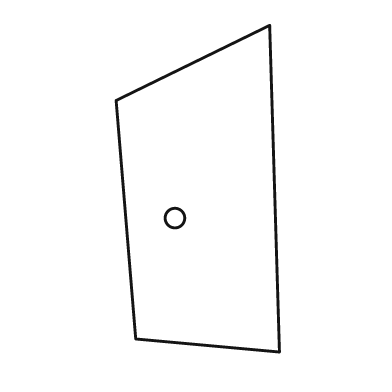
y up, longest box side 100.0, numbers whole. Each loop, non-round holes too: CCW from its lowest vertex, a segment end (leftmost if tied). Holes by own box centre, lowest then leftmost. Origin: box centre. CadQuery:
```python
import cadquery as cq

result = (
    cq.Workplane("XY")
    .moveTo(25.0, -50.0)
    .lineTo(22.0, 50.0)
    .lineTo(-25.0, 27.0)
    .lineTo(-19.0, -46.0)
    .close()
    .moveTo(-7.0, -9.0)
    .circle(3.0)
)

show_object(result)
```